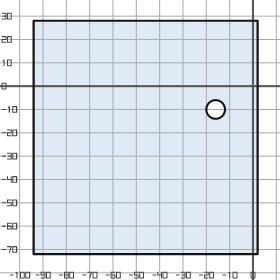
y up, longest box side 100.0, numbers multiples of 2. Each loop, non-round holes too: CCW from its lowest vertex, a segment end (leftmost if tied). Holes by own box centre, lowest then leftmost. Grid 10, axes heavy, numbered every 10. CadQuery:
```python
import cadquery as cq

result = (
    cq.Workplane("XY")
    .moveTo(-94.0, -72.0)
    .lineTo(2.0, -72.0)
    .lineTo(2.0, 28.0)
    .lineTo(-94.0, 28.0)
    .close()
    .moveTo(-16.0, -10.0)
    .circle(4.0)
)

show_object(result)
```